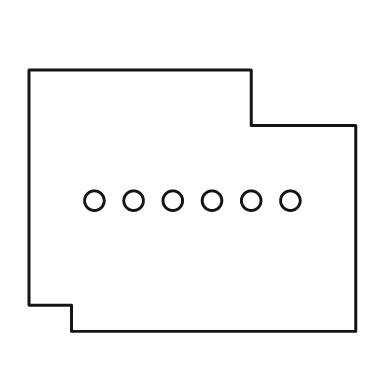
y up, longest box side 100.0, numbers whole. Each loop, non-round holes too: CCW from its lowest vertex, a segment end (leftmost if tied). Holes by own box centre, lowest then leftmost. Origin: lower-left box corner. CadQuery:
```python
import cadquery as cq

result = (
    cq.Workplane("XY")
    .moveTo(13.0, 0.0)
    .lineTo(100.0, 0.0)
    .lineTo(100.0, 63.0)
    .lineTo(68.0, 63.0)
    .lineTo(68.0, 80.0)
    .lineTo(0.0, 80.0)
    .lineTo(0.0, 8.0)
    .lineTo(13.0, 8.0)
    .close()
    .moveTo(20.0, 40.0)
    .circle(3.0)
    .moveTo(32.0, 40.0)
    .circle(3.0)
    .moveTo(44.0, 40.0)
    .circle(3.0)
    .moveTo(56.0, 40.0)
    .circle(3.0)
    .moveTo(68.0, 40.0)
    .circle(3.0)
    .moveTo(80.0, 40.0)
    .circle(3.0)
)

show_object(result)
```